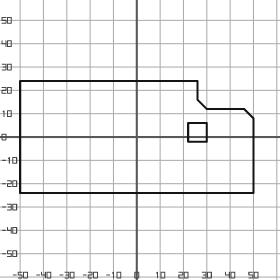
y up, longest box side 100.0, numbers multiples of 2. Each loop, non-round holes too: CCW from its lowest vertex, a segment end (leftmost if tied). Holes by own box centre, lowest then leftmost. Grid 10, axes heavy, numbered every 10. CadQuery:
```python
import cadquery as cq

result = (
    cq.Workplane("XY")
    .moveTo(-50.0, -24.0)
    .lineTo(50.0, -24.0)
    .lineTo(50.0, 8.0)
    .lineTo(46.0, 12.0)
    .lineTo(30.0, 12.0)
    .lineTo(26.0, 16.0)
    .lineTo(26.0, 24.0)
    .lineTo(-50.0, 24.0)
    .close()
    .moveTo(22.0, -2.0)
    .lineTo(30.0, -2.0)
    .lineTo(30.0, 6.0)
    .lineTo(22.0, 6.0)
    .close()
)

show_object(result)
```